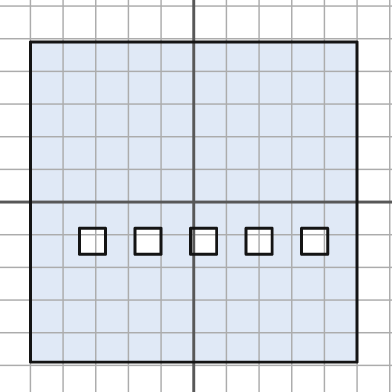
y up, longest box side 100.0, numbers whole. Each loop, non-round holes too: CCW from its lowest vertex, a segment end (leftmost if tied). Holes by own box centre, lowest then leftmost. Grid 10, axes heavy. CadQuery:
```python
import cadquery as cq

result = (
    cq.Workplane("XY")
    .moveTo(-50.0, -49.0)
    .lineTo(50.0, -49.0)
    .lineTo(50.0, 49.0)
    .lineTo(-50.0, 49.0)
    .close()
    .moveTo(-35.0, -16.0)
    .lineTo(-27.0, -16.0)
    .lineTo(-27.0, -8.0)
    .lineTo(-35.0, -8.0)
    .close()
    .moveTo(-18.0, -16.0)
    .lineTo(-10.0, -16.0)
    .lineTo(-10.0, -8.0)
    .lineTo(-18.0, -8.0)
    .close()
    .moveTo(-1.0, -16.0)
    .lineTo(7.0, -16.0)
    .lineTo(7.0, -8.0)
    .lineTo(-1.0, -8.0)
    .close()
    .moveTo(16.0, -16.0)
    .lineTo(24.0, -16.0)
    .lineTo(24.0, -8.0)
    .lineTo(16.0, -8.0)
    .close()
    .moveTo(33.0, -16.0)
    .lineTo(41.0, -16.0)
    .lineTo(41.0, -8.0)
    .lineTo(33.0, -8.0)
    .close()
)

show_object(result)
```